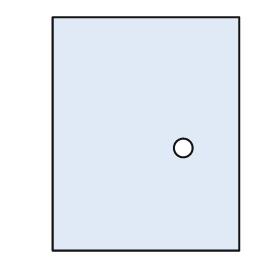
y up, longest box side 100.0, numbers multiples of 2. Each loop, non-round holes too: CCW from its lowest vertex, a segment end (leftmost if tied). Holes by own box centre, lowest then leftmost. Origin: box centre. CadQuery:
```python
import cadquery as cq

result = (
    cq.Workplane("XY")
    .moveTo(-40.0, -50.0)
    .lineTo(40.0, -50.0)
    .lineTo(40.0, 50.0)
    .lineTo(-40.0, 50.0)
    .close()
    .moveTo(16.0, -6.0)
    .circle(4.0)
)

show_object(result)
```